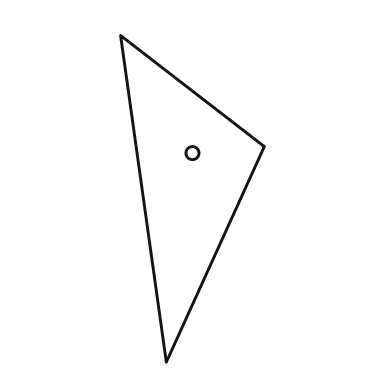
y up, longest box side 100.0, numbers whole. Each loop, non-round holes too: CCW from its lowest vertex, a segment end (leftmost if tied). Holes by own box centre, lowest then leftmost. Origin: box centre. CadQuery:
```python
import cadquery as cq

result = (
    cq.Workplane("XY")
    .moveTo(-8.0, -50.0)
    .lineTo(22.0, 16.0)
    .lineTo(-22.0, 50.0)
    .close()
    .moveTo(0.0, 14.0)
    .circle(2.0)
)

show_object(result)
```